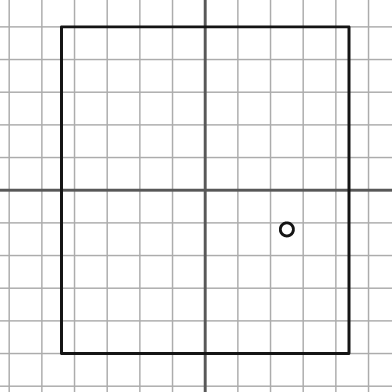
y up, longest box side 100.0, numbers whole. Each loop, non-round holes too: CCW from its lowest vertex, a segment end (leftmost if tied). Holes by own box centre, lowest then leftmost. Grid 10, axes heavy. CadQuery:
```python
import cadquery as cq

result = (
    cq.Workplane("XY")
    .moveTo(-44.0, -50.0)
    .lineTo(44.0, -50.0)
    .lineTo(44.0, 50.0)
    .lineTo(-44.0, 50.0)
    .close()
    .moveTo(25.0, -12.0)
    .circle(2.0)
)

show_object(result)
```